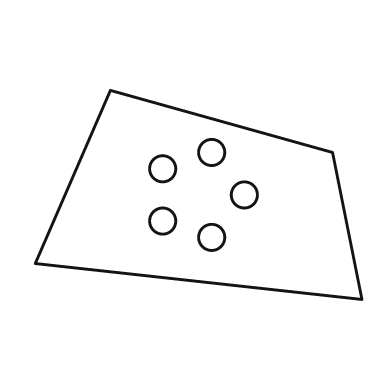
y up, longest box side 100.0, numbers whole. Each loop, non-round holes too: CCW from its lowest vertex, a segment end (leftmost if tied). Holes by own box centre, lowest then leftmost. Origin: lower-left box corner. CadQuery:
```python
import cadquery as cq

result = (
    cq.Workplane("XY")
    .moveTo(100.0, 0.0)
    .lineTo(91.0, 45.0)
    .lineTo(23.0, 64.0)
    .lineTo(0.0, 11.0)
    .close()
    .moveTo(54.0, 19.0)
    .circle(4.0)
    .moveTo(39.0, 24.0)
    .circle(4.0)
    .moveTo(64.0, 32.0)
    .circle(4.0)
    .moveTo(39.0, 40.0)
    .circle(4.0)
    .moveTo(54.0, 45.0)
    .circle(4.0)
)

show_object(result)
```